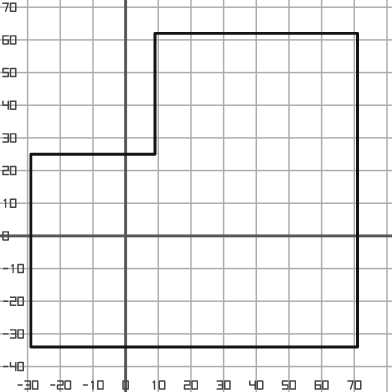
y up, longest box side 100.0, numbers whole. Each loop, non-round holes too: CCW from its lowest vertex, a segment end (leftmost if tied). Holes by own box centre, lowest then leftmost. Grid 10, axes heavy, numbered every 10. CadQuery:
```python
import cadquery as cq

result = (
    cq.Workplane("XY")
    .moveTo(-29.0, -34.0)
    .lineTo(71.0, -34.0)
    .lineTo(71.0, 62.0)
    .lineTo(9.0, 62.0)
    .lineTo(9.0, 25.0)
    .lineTo(-29.0, 25.0)
    .close()
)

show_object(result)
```